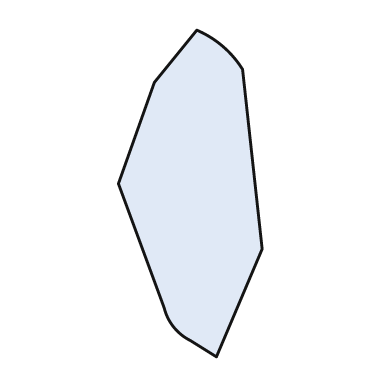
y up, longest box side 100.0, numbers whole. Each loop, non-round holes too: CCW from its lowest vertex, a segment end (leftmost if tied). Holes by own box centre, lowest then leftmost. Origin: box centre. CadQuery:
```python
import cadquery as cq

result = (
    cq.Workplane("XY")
    .moveTo(8.0, -50.0)
    .lineTo(22.0, -17.0)
    .lineTo(16.0, 38.0)
    .threePointArc((10.0, 45.0), (2.0, 50.0))
    .lineTo(-11.0, 34.0)
    .lineTo(-22.0, 3.0)
    .lineTo(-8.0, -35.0)
    .threePointArc((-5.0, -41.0), (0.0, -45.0))
    .close()
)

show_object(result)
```